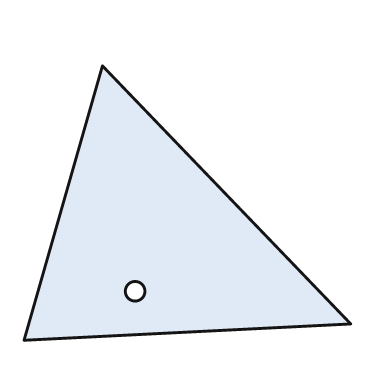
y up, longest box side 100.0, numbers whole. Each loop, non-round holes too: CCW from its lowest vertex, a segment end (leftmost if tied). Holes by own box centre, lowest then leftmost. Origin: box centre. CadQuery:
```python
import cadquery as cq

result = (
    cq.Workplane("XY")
    .moveTo(-50.0, -42.0)
    .lineTo(50.0, -37.0)
    .lineTo(-26.0, 42.0)
    .close()
    .moveTo(-16.0, -27.0)
    .circle(3.0)
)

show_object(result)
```